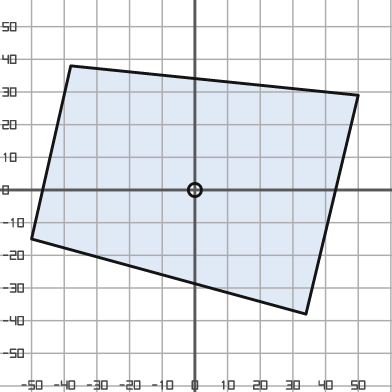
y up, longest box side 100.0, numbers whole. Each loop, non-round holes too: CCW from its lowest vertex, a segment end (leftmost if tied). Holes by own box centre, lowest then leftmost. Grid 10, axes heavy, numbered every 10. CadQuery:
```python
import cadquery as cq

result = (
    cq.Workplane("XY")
    .moveTo(34.0, -38.0)
    .lineTo(50.0, 29.0)
    .lineTo(-38.0, 38.0)
    .lineTo(-50.0, -15.0)
    .close()
    .moveTo(0.0, 0.0)
    .circle(2.0)
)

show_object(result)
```